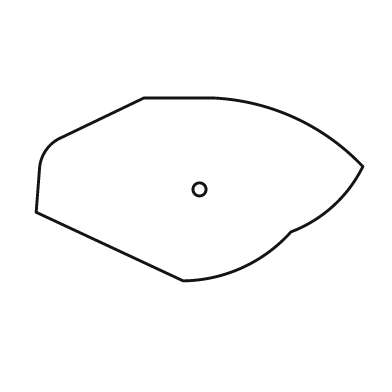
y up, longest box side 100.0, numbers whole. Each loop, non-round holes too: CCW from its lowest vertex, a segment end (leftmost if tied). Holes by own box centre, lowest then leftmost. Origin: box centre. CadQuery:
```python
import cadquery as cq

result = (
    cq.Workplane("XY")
    .moveTo(-5.0, -28.0)
    .threePointArc((13.0, -24.0), (28.0, -13.0))
    .threePointArc((41.0, -5.0), (50.0, 7.0))
    .threePointArc((29.0, 22.0), (4.0, 28.0))
    .lineTo(-17.0, 28.0)
    .lineTo(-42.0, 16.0)
    .threePointArc((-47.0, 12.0), (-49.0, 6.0))
    .lineTo(-50.0, -7.0)
    .close()
    .moveTo(0.0, 0.0)
    .circle(2.0)
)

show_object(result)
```